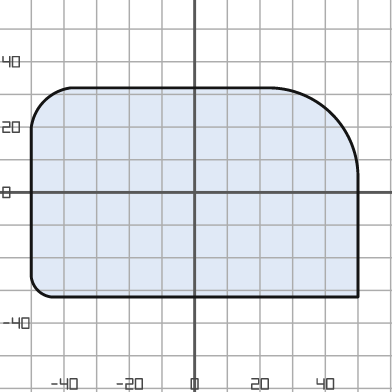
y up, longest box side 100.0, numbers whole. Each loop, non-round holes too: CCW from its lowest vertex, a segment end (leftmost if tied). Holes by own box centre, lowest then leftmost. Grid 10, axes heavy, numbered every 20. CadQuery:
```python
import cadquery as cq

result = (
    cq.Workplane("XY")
    .moveTo(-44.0, -32.0)
    .lineTo(50.0, -32.0)
    .lineTo(50.0, 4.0)
    .threePointArc((42.0, 24.0), (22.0, 32.0))
    .lineTo(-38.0, 32.0)
    .threePointArc((-46.0, 28.0), (-50.0, 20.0))
    .lineTo(-50.0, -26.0)
    .threePointArc((-48.0, -30.0), (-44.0, -32.0))
    .close()
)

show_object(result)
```